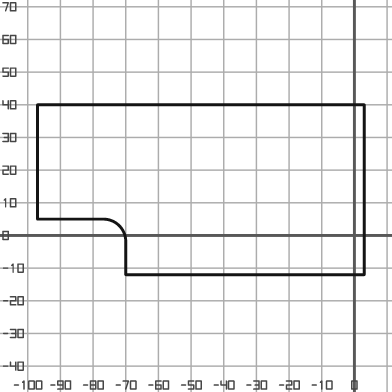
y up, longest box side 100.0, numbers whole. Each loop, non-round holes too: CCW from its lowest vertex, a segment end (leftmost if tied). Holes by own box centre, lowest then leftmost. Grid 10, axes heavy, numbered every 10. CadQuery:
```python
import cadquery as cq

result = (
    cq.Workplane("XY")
    .moveTo(-70.0, -12.0)
    .lineTo(3.0, -12.0)
    .lineTo(3.0, 40.0)
    .lineTo(-97.0, 40.0)
    .lineTo(-97.0, 5.0)
    .lineTo(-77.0, 5.0)
    .threePointArc((-72.0, 3.0), (-70.0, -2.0))
    .close()
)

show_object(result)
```